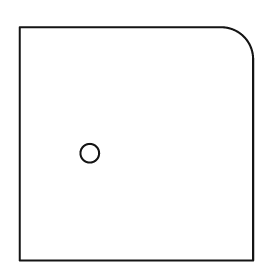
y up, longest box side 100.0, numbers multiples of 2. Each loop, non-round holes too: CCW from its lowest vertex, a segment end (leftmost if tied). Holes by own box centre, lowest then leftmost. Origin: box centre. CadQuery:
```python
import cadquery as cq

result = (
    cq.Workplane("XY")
    .moveTo(-50.0, -50.0)
    .lineTo(50.0, -50.0)
    .lineTo(50.0, 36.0)
    .threePointArc((46.0, 46.0), (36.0, 50.0))
    .lineTo(-50.0, 50.0)
    .close()
    .moveTo(-20.0, -4.0)
    .circle(4.0)
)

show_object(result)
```